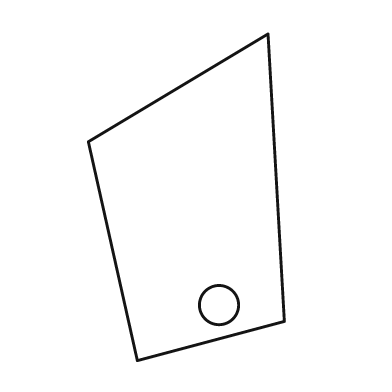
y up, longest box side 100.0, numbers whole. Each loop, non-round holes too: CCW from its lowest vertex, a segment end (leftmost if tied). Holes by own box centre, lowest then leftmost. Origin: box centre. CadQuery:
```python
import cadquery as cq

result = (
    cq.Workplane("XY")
    .moveTo(-15.0, -50.0)
    .lineTo(30.0, -38.0)
    .lineTo(25.0, 50.0)
    .lineTo(-30.0, 17.0)
    .close()
    .moveTo(10.0, -33.0)
    .circle(6.0)
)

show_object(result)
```